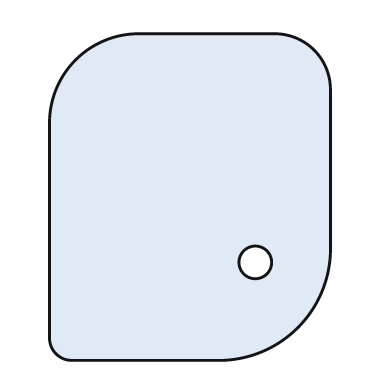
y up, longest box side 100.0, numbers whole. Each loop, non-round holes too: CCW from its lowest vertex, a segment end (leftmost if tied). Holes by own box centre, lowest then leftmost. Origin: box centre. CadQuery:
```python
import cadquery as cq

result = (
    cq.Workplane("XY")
    .moveTo(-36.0, -50.0)
    .lineTo(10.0, -50.0)
    .threePointArc((33.0, -40.0), (43.0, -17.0))
    .lineTo(43.0, 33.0)
    .threePointArc((38.0, 45.0), (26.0, 50.0))
    .lineTo(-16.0, 50.0)
    .threePointArc((-35.0, 42.0), (-43.0, 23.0))
    .lineTo(-43.0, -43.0)
    .threePointArc((-41.0, -48.0), (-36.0, -50.0))
    .close()
    .moveTo(20.0, -20.0)
    .circle(5.0)
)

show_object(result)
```